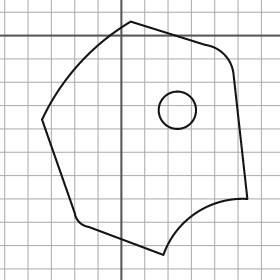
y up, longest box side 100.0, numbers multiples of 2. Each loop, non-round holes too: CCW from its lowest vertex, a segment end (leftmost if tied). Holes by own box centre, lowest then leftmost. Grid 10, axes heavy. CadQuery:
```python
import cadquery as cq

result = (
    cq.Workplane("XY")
    .moveTo(18.0, -94.0)
    .threePointArc((32.0, -76.0), (54.0, -70.0))
    .lineTo(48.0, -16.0)
    .threePointArc((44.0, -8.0), (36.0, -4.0))
    .lineTo(4.0, 6.0)
    .threePointArc((-18.0, -12.0), (-34.0, -36.0))
    .lineTo(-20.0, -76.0)
    .threePointArc((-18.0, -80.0), (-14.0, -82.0))
    .close()
    .moveTo(24.0, -32.0)
    .circle(8.0)
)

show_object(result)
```